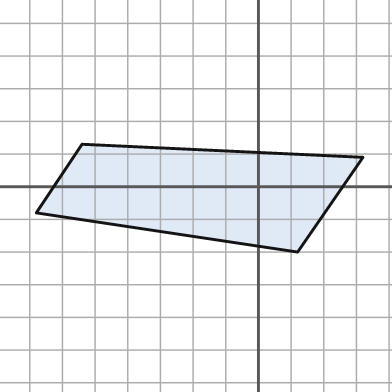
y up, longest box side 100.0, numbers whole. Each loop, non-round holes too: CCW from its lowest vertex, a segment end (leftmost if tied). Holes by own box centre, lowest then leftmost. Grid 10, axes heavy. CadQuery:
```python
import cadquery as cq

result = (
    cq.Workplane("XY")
    .moveTo(12.0, -20.0)
    .lineTo(32.0, 9.0)
    .lineTo(-54.0, 13.0)
    .lineTo(-68.0, -8.0)
    .close()
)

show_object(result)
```